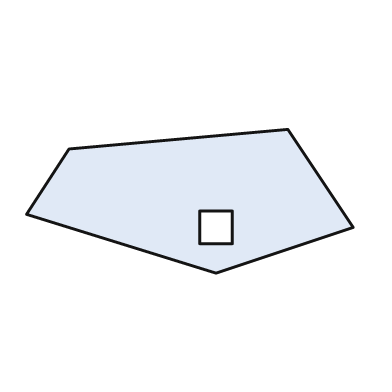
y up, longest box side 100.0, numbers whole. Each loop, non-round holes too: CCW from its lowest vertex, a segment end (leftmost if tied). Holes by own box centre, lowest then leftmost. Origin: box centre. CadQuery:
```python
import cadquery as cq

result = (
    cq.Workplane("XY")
    .moveTo(8.0, -22.0)
    .lineTo(50.0, -8.0)
    .lineTo(30.0, 22.0)
    .lineTo(-37.0, 16.0)
    .lineTo(-50.0, -4.0)
    .close()
    .moveTo(3.0, -13.0)
    .lineTo(13.0, -13.0)
    .lineTo(13.0, -3.0)
    .lineTo(3.0, -3.0)
    .close()
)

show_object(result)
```